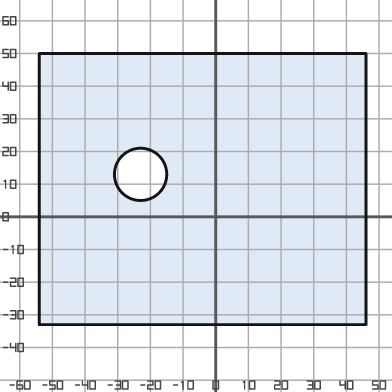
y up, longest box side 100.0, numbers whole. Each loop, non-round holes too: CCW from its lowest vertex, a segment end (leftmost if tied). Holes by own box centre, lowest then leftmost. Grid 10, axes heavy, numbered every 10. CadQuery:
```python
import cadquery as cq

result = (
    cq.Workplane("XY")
    .moveTo(-54.0, -33.0)
    .lineTo(46.0, -33.0)
    .lineTo(46.0, 50.0)
    .lineTo(-54.0, 50.0)
    .close()
    .moveTo(-23.0, 13.0)
    .circle(8.0)
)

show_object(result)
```